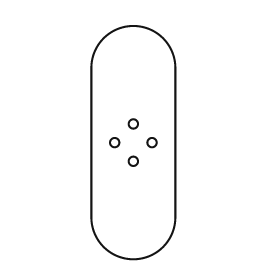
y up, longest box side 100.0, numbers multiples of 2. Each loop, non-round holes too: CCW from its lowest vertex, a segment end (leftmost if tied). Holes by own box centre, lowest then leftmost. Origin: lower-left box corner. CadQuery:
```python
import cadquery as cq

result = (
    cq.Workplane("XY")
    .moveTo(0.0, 18.0)
    .threePointArc((18.0, 0.0), (36.0, 18.0))
    .lineTo(36.0, 82.0)
    .threePointArc((18.0, 100.0), (0.0, 82.0))
    .close()
    .moveTo(18.0, 42.0)
    .circle(2.0)
    .moveTo(10.0, 50.0)
    .circle(2.0)
    .moveTo(26.0, 50.0)
    .circle(2.0)
    .moveTo(18.0, 58.0)
    .circle(2.0)
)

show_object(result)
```